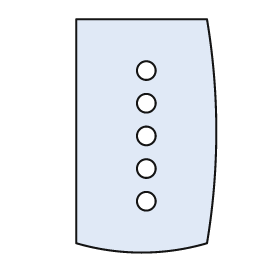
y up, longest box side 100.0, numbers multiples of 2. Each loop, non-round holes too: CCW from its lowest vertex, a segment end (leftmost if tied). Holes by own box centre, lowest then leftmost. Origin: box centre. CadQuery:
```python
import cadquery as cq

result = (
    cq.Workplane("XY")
    .moveTo(-30.0, -46.0)
    .threePointArc((-2.0, -50.0), (26.0, -46.0))
    .threePointArc((30.0, 2.0), (26.0, 50.0))
    .lineTo(-30.0, 50.0)
    .close()
    .moveTo(0.0, -28.0)
    .circle(4.0)
    .moveTo(0.0, -14.0)
    .circle(4.0)
    .moveTo(0.0, 0.0)
    .circle(4.0)
    .moveTo(0.0, 14.0)
    .circle(4.0)
    .moveTo(0.0, 28.0)
    .circle(4.0)
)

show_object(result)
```